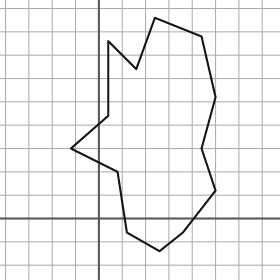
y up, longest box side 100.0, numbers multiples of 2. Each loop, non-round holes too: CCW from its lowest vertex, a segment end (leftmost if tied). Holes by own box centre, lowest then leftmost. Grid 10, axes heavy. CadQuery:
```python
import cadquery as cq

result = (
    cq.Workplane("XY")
    .moveTo(26.0, -14.0)
    .lineTo(36.0, -6.0)
    .lineTo(50.0, 12.0)
    .lineTo(44.0, 30.0)
    .lineTo(50.0, 52.0)
    .lineTo(44.0, 78.0)
    .lineTo(24.0, 86.0)
    .lineTo(16.0, 64.0)
    .lineTo(4.0, 76.0)
    .lineTo(4.0, 44.0)
    .lineTo(-12.0, 30.0)
    .lineTo(8.0, 20.0)
    .lineTo(12.0, -6.0)
    .close()
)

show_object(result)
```